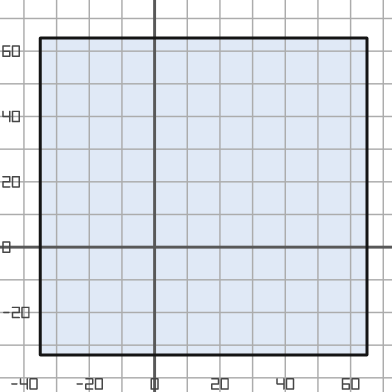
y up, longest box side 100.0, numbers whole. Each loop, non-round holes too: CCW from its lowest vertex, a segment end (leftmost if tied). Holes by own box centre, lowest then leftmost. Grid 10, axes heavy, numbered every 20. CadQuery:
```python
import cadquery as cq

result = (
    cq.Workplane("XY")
    .moveTo(-35.0, -33.0)
    .lineTo(65.0, -33.0)
    .lineTo(65.0, 64.0)
    .lineTo(-35.0, 64.0)
    .close()
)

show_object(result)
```